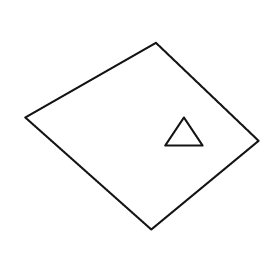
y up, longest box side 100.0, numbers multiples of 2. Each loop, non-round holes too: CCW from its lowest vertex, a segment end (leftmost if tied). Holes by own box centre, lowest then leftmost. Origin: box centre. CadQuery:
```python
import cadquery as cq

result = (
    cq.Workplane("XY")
    .moveTo(4.0, -40.0)
    .lineTo(50.0, -2.0)
    .lineTo(6.0, 40.0)
    .lineTo(-50.0, 8.0)
    .close()
    .moveTo(10.0, -4.0)
    .lineTo(26.0, -4.0)
    .lineTo(18.0, 8.0)
    .close()
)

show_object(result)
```